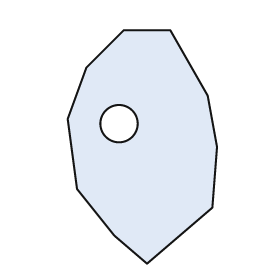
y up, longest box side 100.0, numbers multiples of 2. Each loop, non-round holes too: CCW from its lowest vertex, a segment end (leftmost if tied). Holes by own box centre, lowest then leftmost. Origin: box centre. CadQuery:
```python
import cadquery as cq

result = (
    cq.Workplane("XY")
    .moveTo(2.0, -50.0)
    .lineTo(30.0, -26.0)
    .lineTo(32.0, 0.0)
    .lineTo(28.0, 22.0)
    .lineTo(12.0, 50.0)
    .lineTo(-8.0, 50.0)
    .lineTo(-24.0, 34.0)
    .lineTo(-32.0, 12.0)
    .lineTo(-28.0, -18.0)
    .lineTo(-12.0, -38.0)
    .close()
    .moveTo(-10.0, 10.0)
    .circle(8.0)
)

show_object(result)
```